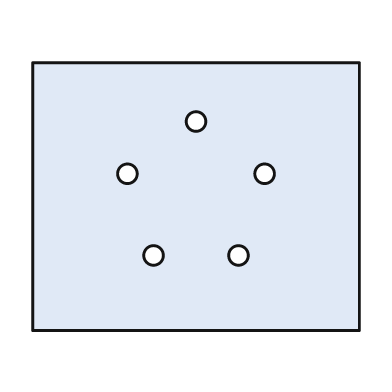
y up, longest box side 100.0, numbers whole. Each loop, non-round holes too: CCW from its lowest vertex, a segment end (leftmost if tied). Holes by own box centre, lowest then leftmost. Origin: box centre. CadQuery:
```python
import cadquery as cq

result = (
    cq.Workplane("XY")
    .moveTo(-50.0, -41.0)
    .lineTo(50.0, -41.0)
    .lineTo(50.0, 41.0)
    .lineTo(-50.0, 41.0)
    .close()
    .moveTo(-13.0, -18.0)
    .circle(3.0)
    .moveTo(13.0, -18.0)
    .circle(3.0)
    .moveTo(-21.0, 7.0)
    .circle(3.0)
    .moveTo(21.0, 7.0)
    .circle(3.0)
    .moveTo(0.0, 23.0)
    .circle(3.0)
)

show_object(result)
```